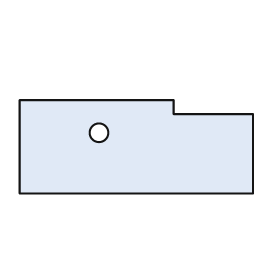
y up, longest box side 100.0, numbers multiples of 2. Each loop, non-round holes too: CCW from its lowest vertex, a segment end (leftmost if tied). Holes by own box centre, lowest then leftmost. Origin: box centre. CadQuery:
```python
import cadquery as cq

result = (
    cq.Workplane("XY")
    .moveTo(-50.0, -20.0)
    .lineTo(50.0, -20.0)
    .lineTo(50.0, 14.0)
    .lineTo(16.0, 14.0)
    .lineTo(16.0, 20.0)
    .lineTo(-50.0, 20.0)
    .close()
    .moveTo(-16.0, 6.0)
    .circle(4.0)
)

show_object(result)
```